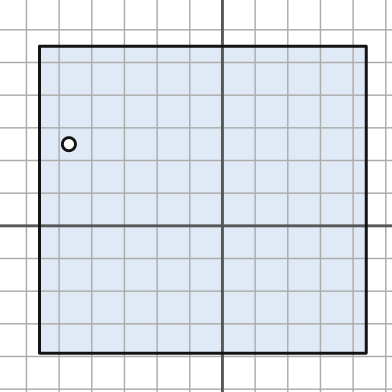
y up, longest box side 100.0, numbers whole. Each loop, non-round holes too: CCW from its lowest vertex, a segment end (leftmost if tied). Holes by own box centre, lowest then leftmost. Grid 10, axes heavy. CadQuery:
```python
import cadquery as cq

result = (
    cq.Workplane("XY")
    .moveTo(-56.0, -39.0)
    .lineTo(44.0, -39.0)
    .lineTo(44.0, 55.0)
    .lineTo(-56.0, 55.0)
    .close()
    .moveTo(-47.0, 25.0)
    .circle(2.0)
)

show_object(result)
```